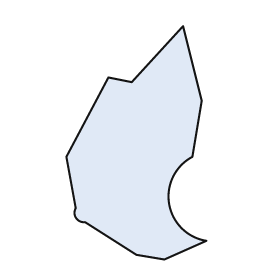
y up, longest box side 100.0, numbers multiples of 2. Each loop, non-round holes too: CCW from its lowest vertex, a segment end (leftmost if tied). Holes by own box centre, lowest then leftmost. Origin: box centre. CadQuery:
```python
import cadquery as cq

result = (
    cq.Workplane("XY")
    .moveTo(12.0, -50.0)
    .lineTo(30.0, -42.0)
    .threePointArc((14.0, -26.0), (24.0, -6.0))
    .lineTo(28.0, 18.0)
    .lineTo(20.0, 50.0)
    .lineTo(-2.0, 26.0)
    .lineTo(-12.0, 28.0)
    .lineTo(-30.0, -6.0)
    .lineTo(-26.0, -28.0)
    .threePointArc((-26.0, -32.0), (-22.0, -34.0))
    .lineTo(0.0, -48.0)
    .close()
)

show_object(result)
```